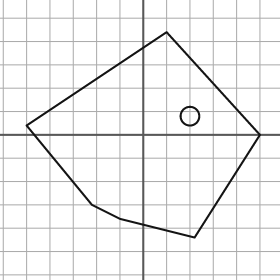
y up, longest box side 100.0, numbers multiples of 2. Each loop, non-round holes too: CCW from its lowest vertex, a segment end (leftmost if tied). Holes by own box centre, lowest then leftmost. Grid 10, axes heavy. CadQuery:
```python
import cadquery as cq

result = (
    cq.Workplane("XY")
    .moveTo(22.0, -44.0)
    .lineTo(50.0, 0.0)
    .lineTo(10.0, 44.0)
    .lineTo(-50.0, 4.0)
    .lineTo(-22.0, -30.0)
    .lineTo(-10.0, -36.0)
    .close()
    .moveTo(20.0, 8.0)
    .circle(4.0)
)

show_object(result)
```